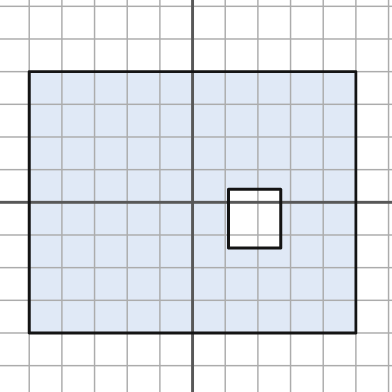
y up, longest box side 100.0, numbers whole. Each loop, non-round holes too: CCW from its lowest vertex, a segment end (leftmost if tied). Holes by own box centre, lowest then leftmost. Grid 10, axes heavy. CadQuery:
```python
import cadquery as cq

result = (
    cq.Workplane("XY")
    .moveTo(-50.0, -40.0)
    .lineTo(50.0, -40.0)
    .lineTo(50.0, 40.0)
    .lineTo(-50.0, 40.0)
    .close()
    .moveTo(11.0, -14.0)
    .lineTo(27.0, -14.0)
    .lineTo(27.0, 4.0)
    .lineTo(11.0, 4.0)
    .close()
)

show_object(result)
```